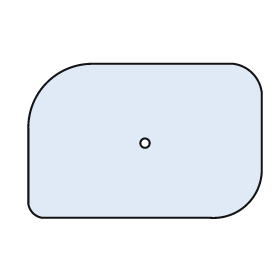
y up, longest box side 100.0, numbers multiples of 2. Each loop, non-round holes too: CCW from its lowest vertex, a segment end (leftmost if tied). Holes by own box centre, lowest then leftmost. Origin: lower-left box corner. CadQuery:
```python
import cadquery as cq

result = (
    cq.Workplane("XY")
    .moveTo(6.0, 0.0)
    .lineTo(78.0, 0.0)
    .threePointArc((94.0, 6.0), (100.0, 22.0))
    .lineTo(100.0, 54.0)
    .threePointArc((96.0, 62.0), (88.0, 66.0))
    .lineTo(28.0, 66.0)
    .threePointArc((8.0, 58.0), (0.0, 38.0))
    .lineTo(0.0, 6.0)
    .threePointArc((2.0, 2.0), (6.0, 0.0))
    .close()
    .moveTo(50.0, 32.0)
    .circle(2.0)
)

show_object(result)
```